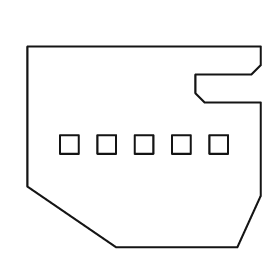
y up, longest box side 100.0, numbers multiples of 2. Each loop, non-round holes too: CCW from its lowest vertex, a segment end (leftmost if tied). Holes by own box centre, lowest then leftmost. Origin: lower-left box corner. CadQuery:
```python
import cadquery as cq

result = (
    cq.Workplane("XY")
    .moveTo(38.0, 0.0)
    .lineTo(90.0, 0.0)
    .lineTo(100.0, 22.0)
    .lineTo(100.0, 62.0)
    .lineTo(76.0, 62.0)
    .lineTo(72.0, 66.0)
    .lineTo(72.0, 74.0)
    .lineTo(96.0, 74.0)
    .lineTo(100.0, 78.0)
    .lineTo(100.0, 86.0)
    .lineTo(0.0, 86.0)
    .lineTo(0.0, 26.0)
    .close()
    .moveTo(14.0, 40.0)
    .lineTo(22.0, 40.0)
    .lineTo(22.0, 48.0)
    .lineTo(14.0, 48.0)
    .close()
    .moveTo(30.0, 40.0)
    .lineTo(38.0, 40.0)
    .lineTo(38.0, 48.0)
    .lineTo(30.0, 48.0)
    .close()
    .moveTo(46.0, 40.0)
    .lineTo(54.0, 40.0)
    .lineTo(54.0, 48.0)
    .lineTo(46.0, 48.0)
    .close()
    .moveTo(62.0, 40.0)
    .lineTo(70.0, 40.0)
    .lineTo(70.0, 48.0)
    .lineTo(62.0, 48.0)
    .close()
    .moveTo(78.0, 40.0)
    .lineTo(86.0, 40.0)
    .lineTo(86.0, 48.0)
    .lineTo(78.0, 48.0)
    .close()
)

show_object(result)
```